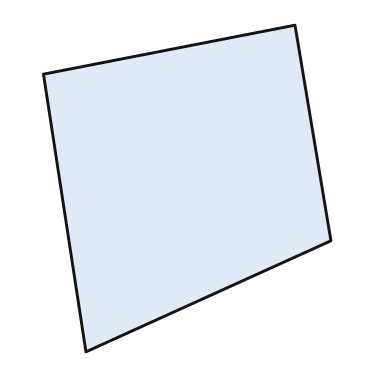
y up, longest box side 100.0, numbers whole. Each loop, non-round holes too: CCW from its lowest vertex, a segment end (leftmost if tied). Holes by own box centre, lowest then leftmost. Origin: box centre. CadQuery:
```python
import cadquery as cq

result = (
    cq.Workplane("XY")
    .moveTo(-31.0, -50.0)
    .lineTo(44.0, -16.0)
    .lineTo(33.0, 50.0)
    .lineTo(-44.0, 35.0)
    .close()
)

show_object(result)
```